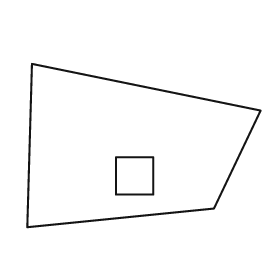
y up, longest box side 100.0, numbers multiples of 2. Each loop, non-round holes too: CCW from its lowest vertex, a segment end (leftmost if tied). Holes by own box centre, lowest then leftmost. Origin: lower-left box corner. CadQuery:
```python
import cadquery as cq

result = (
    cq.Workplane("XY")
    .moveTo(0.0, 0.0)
    .lineTo(80.0, 8.0)
    .lineTo(100.0, 50.0)
    .lineTo(2.0, 70.0)
    .close()
    .moveTo(38.0, 14.0)
    .lineTo(54.0, 14.0)
    .lineTo(54.0, 30.0)
    .lineTo(38.0, 30.0)
    .close()
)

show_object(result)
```